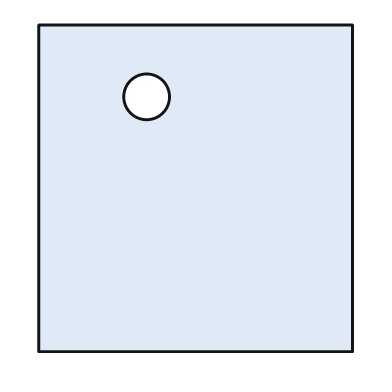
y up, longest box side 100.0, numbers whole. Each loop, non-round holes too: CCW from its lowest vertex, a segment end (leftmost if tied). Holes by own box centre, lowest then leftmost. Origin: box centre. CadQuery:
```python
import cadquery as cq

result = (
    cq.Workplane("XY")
    .moveTo(-48.0, -50.0)
    .lineTo(48.0, -50.0)
    .lineTo(48.0, 50.0)
    .lineTo(-48.0, 50.0)
    .close()
    .moveTo(-15.0, 28.0)
    .circle(7.0)
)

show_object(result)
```